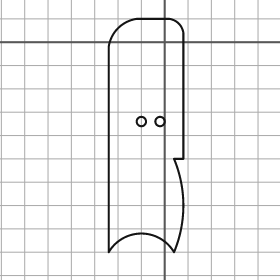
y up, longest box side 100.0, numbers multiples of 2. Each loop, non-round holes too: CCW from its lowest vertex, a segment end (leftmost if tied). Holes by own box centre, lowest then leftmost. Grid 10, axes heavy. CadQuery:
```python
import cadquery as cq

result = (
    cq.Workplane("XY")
    .moveTo(-24.0, -90.0)
    .threePointArc((-10.0, -82.0), (4.0, -90.0))
    .threePointArc((8.0, -70.0), (4.0, -50.0))
    .lineTo(8.0, -50.0)
    .lineTo(8.0, 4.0)
    .threePointArc((6.0, 8.0), (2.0, 10.0))
    .lineTo(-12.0, 10.0)
    .threePointArc((-20.0, 6.0), (-24.0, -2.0))
    .close()
    .moveTo(-10.0, -34.0)
    .circle(2.0)
    .moveTo(-2.0, -34.0)
    .circle(2.0)
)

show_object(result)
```